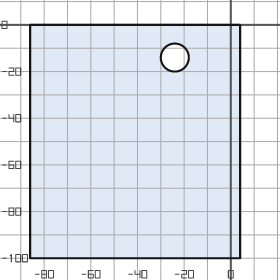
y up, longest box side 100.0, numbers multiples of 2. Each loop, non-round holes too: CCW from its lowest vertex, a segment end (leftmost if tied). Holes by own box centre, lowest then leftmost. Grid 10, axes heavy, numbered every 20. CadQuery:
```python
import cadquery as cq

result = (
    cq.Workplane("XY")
    .moveTo(-86.0, -100.0)
    .lineTo(4.0, -100.0)
    .lineTo(4.0, 0.0)
    .lineTo(-86.0, 0.0)
    .close()
    .moveTo(-24.0, -14.0)
    .circle(6.0)
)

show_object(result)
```